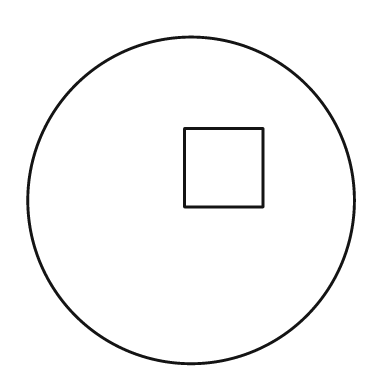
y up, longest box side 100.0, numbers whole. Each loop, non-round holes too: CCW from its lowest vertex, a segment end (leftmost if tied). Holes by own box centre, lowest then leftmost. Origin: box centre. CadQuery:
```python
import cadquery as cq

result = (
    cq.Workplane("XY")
    .moveTo(0.0, 0.0)
    .circle(50.0)
    .moveTo(-2.0, -2.0)
    .lineTo(22.0, -2.0)
    .lineTo(22.0, 22.0)
    .lineTo(-2.0, 22.0)
    .close()
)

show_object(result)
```